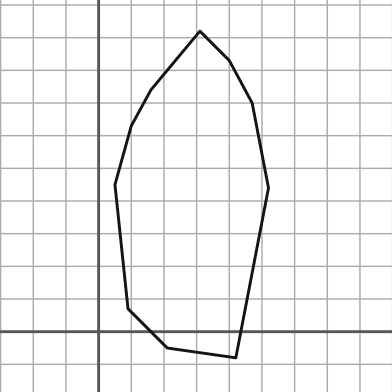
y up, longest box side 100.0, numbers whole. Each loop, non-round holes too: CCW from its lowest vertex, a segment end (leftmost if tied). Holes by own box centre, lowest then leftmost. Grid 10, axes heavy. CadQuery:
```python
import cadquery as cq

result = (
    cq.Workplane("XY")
    .moveTo(42.0, -8.0)
    .lineTo(52.0, 44.0)
    .lineTo(47.0, 70.0)
    .lineTo(40.0, 83.0)
    .lineTo(31.0, 92.0)
    .lineTo(16.0, 74.0)
    .lineTo(10.0, 63.0)
    .lineTo(5.0, 45.0)
    .lineTo(9.0, 7.0)
    .lineTo(21.0, -5.0)
    .close()
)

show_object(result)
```